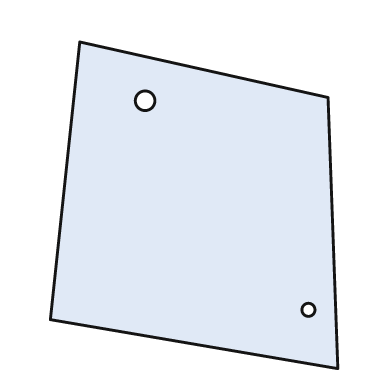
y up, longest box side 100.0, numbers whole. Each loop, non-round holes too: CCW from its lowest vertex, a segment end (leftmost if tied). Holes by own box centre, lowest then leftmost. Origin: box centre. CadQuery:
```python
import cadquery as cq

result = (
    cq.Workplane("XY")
    .moveTo(44.0, -50.0)
    .lineTo(41.0, 33.0)
    .lineTo(-35.0, 50.0)
    .lineTo(-44.0, -35.0)
    .close()
    .moveTo(35.0, -32.0)
    .circle(2.0)
    .moveTo(-15.0, 32.0)
    .circle(3.0)
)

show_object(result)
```